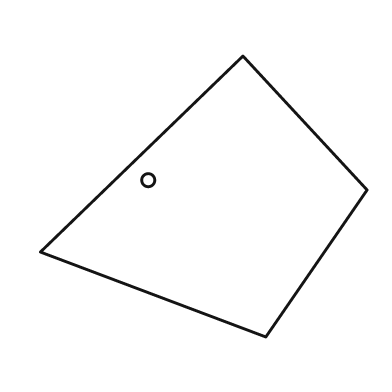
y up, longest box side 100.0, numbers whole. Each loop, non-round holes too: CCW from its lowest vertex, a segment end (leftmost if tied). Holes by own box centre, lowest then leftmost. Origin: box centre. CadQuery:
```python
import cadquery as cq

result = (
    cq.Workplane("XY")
    .moveTo(19.0, -43.0)
    .lineTo(50.0, 2.0)
    .lineTo(12.0, 43.0)
    .lineTo(-50.0, -17.0)
    .close()
    .moveTo(-17.0, 5.0)
    .circle(2.0)
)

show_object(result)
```